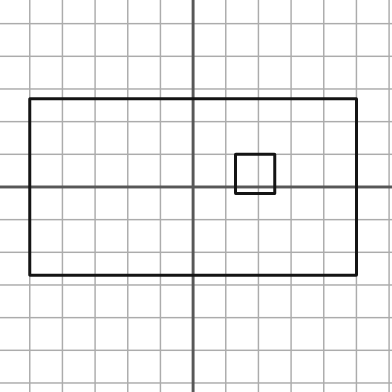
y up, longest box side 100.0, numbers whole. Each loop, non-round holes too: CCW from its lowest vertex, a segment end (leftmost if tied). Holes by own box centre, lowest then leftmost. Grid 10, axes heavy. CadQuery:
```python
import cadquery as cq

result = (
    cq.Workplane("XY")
    .moveTo(-50.0, -27.0)
    .lineTo(50.0, -27.0)
    .lineTo(50.0, 27.0)
    .lineTo(-50.0, 27.0)
    .close()
    .moveTo(13.0, -2.0)
    .lineTo(25.0, -2.0)
    .lineTo(25.0, 10.0)
    .lineTo(13.0, 10.0)
    .close()
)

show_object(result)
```